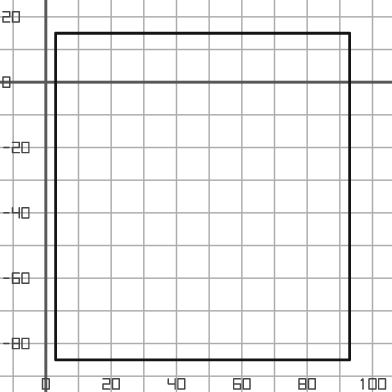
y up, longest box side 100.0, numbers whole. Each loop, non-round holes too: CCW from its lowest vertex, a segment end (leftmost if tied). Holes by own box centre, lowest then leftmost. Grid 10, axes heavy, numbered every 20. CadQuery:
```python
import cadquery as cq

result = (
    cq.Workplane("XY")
    .moveTo(3.0, -85.0)
    .lineTo(93.0, -85.0)
    .lineTo(93.0, 15.0)
    .lineTo(3.0, 15.0)
    .close()
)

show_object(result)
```